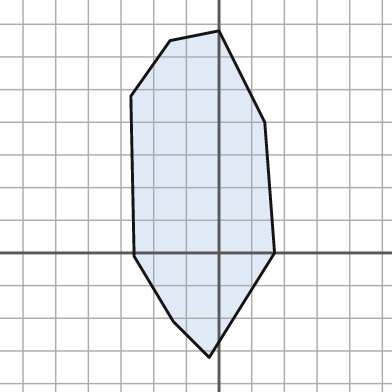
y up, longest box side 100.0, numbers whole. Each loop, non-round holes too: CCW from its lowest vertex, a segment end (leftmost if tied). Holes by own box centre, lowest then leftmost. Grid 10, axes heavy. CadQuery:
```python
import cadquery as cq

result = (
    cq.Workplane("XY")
    .moveTo(-3.0, -32.0)
    .lineTo(17.0, 0.0)
    .lineTo(14.0, 40.0)
    .lineTo(0.0, 68.0)
    .lineTo(-15.0, 65.0)
    .lineTo(-27.0, 48.0)
    .lineTo(-26.0, -1.0)
    .lineTo(-14.0, -21.0)
    .close()
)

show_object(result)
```